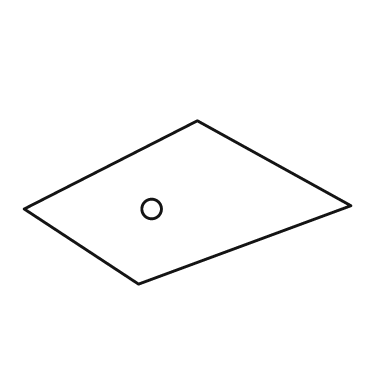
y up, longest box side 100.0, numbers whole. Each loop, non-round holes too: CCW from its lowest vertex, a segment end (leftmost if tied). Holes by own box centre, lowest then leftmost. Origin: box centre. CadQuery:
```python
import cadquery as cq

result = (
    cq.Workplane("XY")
    .moveTo(-15.0, -25.0)
    .lineTo(50.0, -1.0)
    .lineTo(3.0, 25.0)
    .lineTo(-50.0, -2.0)
    .close()
    .moveTo(-11.0, -2.0)
    .circle(3.0)
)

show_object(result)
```